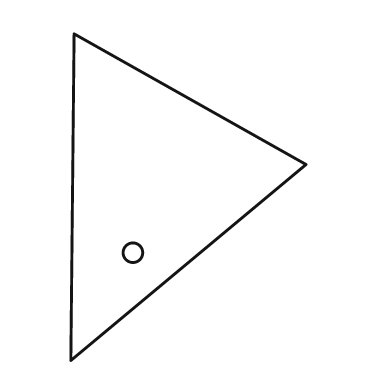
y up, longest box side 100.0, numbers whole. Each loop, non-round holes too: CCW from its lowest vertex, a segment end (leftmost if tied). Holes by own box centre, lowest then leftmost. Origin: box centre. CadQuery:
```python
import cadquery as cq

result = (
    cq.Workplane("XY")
    .moveTo(-36.0, -50.0)
    .lineTo(36.0, 10.0)
    .lineTo(-35.0, 50.0)
    .close()
    .moveTo(-17.0, -17.0)
    .circle(3.0)
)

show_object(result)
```